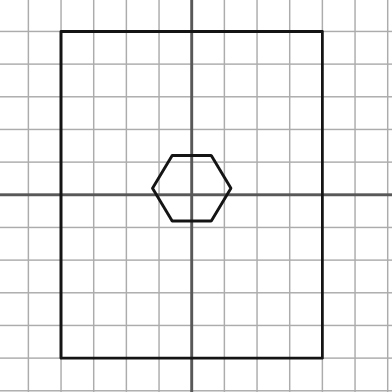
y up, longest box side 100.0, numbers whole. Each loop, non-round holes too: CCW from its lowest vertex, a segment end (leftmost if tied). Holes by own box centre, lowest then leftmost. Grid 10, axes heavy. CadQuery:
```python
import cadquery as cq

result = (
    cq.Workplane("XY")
    .moveTo(-40.0, -50.0)
    .lineTo(40.0, -50.0)
    .lineTo(40.0, 50.0)
    .lineTo(-40.0, 50.0)
    .close()
    .moveTo(-6.0, -8.0)
    .lineTo(6.0, -8.0)
    .lineTo(12.0, 2.0)
    .lineTo(6.0, 12.0)
    .lineTo(-6.0, 12.0)
    .lineTo(-12.0, 2.0)
    .close()
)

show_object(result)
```